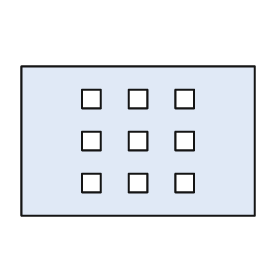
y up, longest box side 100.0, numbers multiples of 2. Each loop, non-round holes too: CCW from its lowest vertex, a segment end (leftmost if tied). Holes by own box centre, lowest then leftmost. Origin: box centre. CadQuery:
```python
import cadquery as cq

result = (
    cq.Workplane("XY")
    .moveTo(-50.0, -32.0)
    .lineTo(50.0, -32.0)
    .lineTo(50.0, 32.0)
    .lineTo(-50.0, 32.0)
    .close()
    .moveTo(-24.0, -22.0)
    .lineTo(-16.0, -22.0)
    .lineTo(-16.0, -14.0)
    .lineTo(-24.0, -14.0)
    .close()
    .moveTo(-4.0, -22.0)
    .lineTo(4.0, -22.0)
    .lineTo(4.0, -14.0)
    .lineTo(-4.0, -14.0)
    .close()
    .moveTo(16.0, -22.0)
    .lineTo(24.0, -22.0)
    .lineTo(24.0, -14.0)
    .lineTo(16.0, -14.0)
    .close()
    .moveTo(-24.0, -4.0)
    .lineTo(-16.0, -4.0)
    .lineTo(-16.0, 4.0)
    .lineTo(-24.0, 4.0)
    .close()
    .moveTo(-4.0, -4.0)
    .lineTo(4.0, -4.0)
    .lineTo(4.0, 4.0)
    .lineTo(-4.0, 4.0)
    .close()
    .moveTo(16.0, -4.0)
    .lineTo(24.0, -4.0)
    .lineTo(24.0, 4.0)
    .lineTo(16.0, 4.0)
    .close()
    .moveTo(-24.0, 14.0)
    .lineTo(-16.0, 14.0)
    .lineTo(-16.0, 22.0)
    .lineTo(-24.0, 22.0)
    .close()
    .moveTo(-4.0, 14.0)
    .lineTo(4.0, 14.0)
    .lineTo(4.0, 22.0)
    .lineTo(-4.0, 22.0)
    .close()
    .moveTo(16.0, 14.0)
    .lineTo(24.0, 14.0)
    .lineTo(24.0, 22.0)
    .lineTo(16.0, 22.0)
    .close()
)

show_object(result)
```